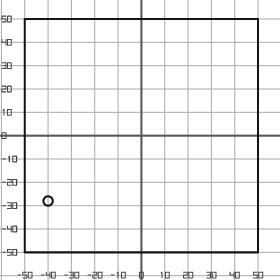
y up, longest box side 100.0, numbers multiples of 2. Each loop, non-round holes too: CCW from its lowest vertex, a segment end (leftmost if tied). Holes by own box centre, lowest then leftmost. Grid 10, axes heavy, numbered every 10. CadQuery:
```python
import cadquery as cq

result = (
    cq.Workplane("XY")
    .moveTo(-50.0, -50.0)
    .lineTo(50.0, -50.0)
    .lineTo(50.0, 50.0)
    .lineTo(-50.0, 50.0)
    .close()
    .moveTo(-40.0, -28.0)
    .circle(2.0)
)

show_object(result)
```